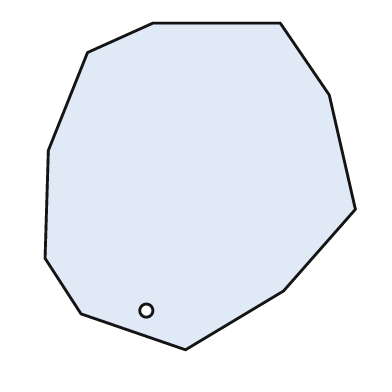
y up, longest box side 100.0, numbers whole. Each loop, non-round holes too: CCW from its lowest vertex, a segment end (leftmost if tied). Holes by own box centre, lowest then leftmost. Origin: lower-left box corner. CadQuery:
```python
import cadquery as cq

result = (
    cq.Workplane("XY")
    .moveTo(43.0, 0.0)
    .lineTo(73.0, 18.0)
    .lineTo(95.0, 43.0)
    .lineTo(87.0, 78.0)
    .lineTo(72.0, 100.0)
    .lineTo(33.0, 100.0)
    .lineTo(13.0, 91.0)
    .lineTo(1.0, 61.0)
    .lineTo(0.0, 28.0)
    .lineTo(11.0, 11.0)
    .close()
    .moveTo(31.0, 12.0)
    .circle(2.0)
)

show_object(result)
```